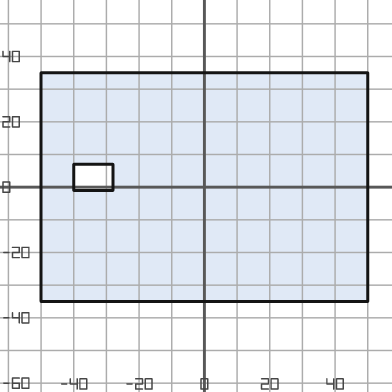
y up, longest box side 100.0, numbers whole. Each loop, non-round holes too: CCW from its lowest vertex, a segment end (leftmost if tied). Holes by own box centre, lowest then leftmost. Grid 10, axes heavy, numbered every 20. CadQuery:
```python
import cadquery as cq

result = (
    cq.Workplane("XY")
    .moveTo(-50.0, -35.0)
    .lineTo(50.0, -35.0)
    .lineTo(50.0, 35.0)
    .lineTo(-50.0, 35.0)
    .close()
    .moveTo(-40.0, -1.0)
    .lineTo(-28.0, -1.0)
    .lineTo(-28.0, 7.0)
    .lineTo(-40.0, 7.0)
    .close()
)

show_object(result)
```